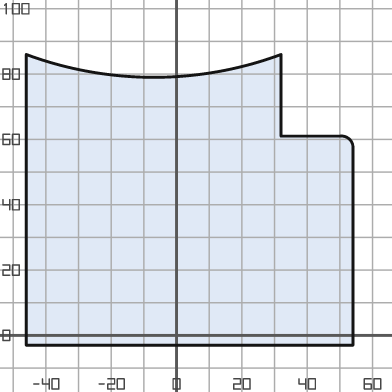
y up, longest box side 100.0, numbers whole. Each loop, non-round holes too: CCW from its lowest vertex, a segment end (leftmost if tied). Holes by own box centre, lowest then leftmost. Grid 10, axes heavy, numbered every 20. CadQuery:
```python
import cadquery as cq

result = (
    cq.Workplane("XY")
    .moveTo(-46.0, -3.0)
    .lineTo(54.0, -3.0)
    .lineTo(54.0, 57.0)
    .threePointArc((53.0, 60.0), (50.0, 61.0))
    .lineTo(32.0, 61.0)
    .lineTo(32.0, 86.0)
    .threePointArc((-7.0, 79.0), (-46.0, 86.0))
    .close()
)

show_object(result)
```